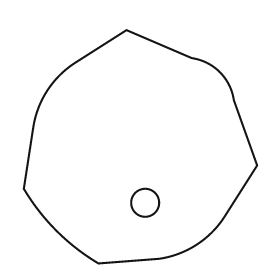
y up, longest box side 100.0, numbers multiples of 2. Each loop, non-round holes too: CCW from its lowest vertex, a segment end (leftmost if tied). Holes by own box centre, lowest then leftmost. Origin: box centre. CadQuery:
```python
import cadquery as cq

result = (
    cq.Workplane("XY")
    .moveTo(-18.0, -50.0)
    .lineTo(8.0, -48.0)
    .threePointArc((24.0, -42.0), (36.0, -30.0))
    .lineTo(50.0, -8.0)
    .lineTo(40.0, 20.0)
    .threePointArc((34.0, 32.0), (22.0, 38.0))
    .lineTo(-6.0, 50.0)
    .lineTo(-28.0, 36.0)
    .threePointArc((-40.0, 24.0), (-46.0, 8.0))
    .lineTo(-50.0, -18.0)
    .threePointArc((-36.0, -36.0), (-18.0, -50.0))
    .close()
    .moveTo(2.0, -24.0)
    .circle(6.0)
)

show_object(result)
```